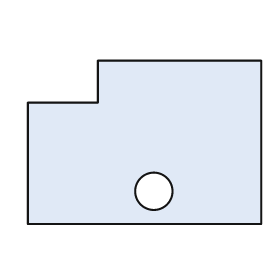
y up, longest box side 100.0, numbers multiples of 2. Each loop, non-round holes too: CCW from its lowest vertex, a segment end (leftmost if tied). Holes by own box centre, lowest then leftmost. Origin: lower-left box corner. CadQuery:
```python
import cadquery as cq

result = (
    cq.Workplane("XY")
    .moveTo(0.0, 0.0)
    .lineTo(100.0, 0.0)
    .lineTo(100.0, 70.0)
    .lineTo(30.0, 70.0)
    .lineTo(30.0, 52.0)
    .lineTo(0.0, 52.0)
    .close()
    .moveTo(54.0, 14.0)
    .circle(8.0)
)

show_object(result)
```